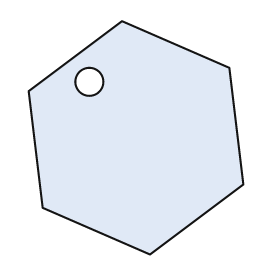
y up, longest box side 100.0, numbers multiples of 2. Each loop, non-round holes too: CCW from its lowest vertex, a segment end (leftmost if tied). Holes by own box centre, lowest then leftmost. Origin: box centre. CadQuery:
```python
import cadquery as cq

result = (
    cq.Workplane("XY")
    .moveTo(6.0, -50.0)
    .lineTo(46.0, -20.0)
    .lineTo(40.0, 30.0)
    .lineTo(-6.0, 50.0)
    .lineTo(-46.0, 20.0)
    .lineTo(-40.0, -30.0)
    .close()
    .moveTo(-20.0, 24.0)
    .circle(6.0)
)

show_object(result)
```